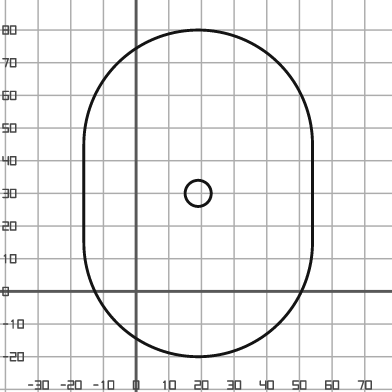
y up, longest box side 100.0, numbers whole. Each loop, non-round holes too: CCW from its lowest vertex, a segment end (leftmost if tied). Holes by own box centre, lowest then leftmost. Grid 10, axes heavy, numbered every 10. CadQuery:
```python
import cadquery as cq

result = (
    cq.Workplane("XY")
    .moveTo(-16.0, 15.0)
    .threePointArc((19.0, -20.0), (54.0, 15.0))
    .lineTo(54.0, 45.0)
    .threePointArc((19.0, 80.0), (-16.0, 45.0))
    .close()
    .moveTo(19.0, 30.0)
    .circle(4.0)
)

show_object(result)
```